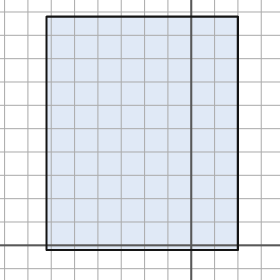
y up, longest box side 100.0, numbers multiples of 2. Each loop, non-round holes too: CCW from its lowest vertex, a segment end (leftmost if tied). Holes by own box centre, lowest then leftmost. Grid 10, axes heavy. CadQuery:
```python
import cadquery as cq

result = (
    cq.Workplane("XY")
    .moveTo(-62.0, -2.0)
    .lineTo(20.0, -2.0)
    .lineTo(20.0, 98.0)
    .lineTo(-62.0, 98.0)
    .close()
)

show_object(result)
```